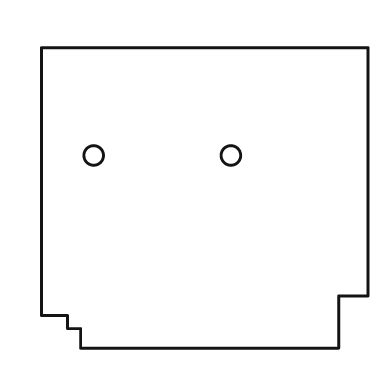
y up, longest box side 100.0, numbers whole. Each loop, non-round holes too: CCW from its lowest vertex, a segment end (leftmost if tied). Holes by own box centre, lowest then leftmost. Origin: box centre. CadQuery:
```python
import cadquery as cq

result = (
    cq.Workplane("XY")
    .moveTo(-38.0, -46.0)
    .lineTo(41.0, -46.0)
    .lineTo(41.0, -30.0)
    .lineTo(50.0, -30.0)
    .lineTo(50.0, 46.0)
    .lineTo(-50.0, 46.0)
    .lineTo(-50.0, -36.0)
    .lineTo(-42.0, -36.0)
    .lineTo(-42.0, -40.0)
    .lineTo(-38.0, -40.0)
    .close()
    .moveTo(-34.0, 13.0)
    .circle(3.0)
    .moveTo(8.0, 13.0)
    .circle(3.0)
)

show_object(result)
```